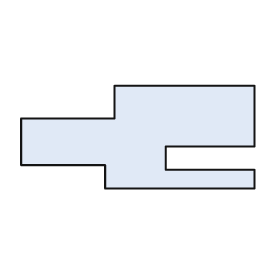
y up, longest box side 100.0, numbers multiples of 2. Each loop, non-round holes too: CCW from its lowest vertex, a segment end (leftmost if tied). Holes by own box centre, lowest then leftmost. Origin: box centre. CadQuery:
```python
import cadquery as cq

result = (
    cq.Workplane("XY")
    .moveTo(-14.0, -22.0)
    .lineTo(50.0, -22.0)
    .lineTo(50.0, -14.0)
    .lineTo(12.0, -14.0)
    .lineTo(12.0, -4.0)
    .lineTo(50.0, -4.0)
    .lineTo(50.0, 22.0)
    .lineTo(-10.0, 22.0)
    .lineTo(-10.0, 8.0)
    .lineTo(-50.0, 8.0)
    .lineTo(-50.0, -12.0)
    .lineTo(-14.0, -12.0)
    .close()
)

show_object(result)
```